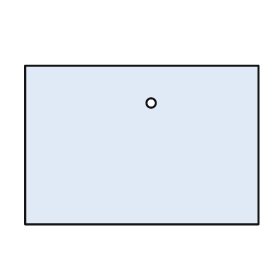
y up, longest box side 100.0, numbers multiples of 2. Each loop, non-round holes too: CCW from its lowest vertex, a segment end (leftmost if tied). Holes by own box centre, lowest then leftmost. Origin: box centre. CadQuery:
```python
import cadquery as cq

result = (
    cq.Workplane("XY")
    .moveTo(-50.0, -34.0)
    .lineTo(50.0, -34.0)
    .lineTo(50.0, 34.0)
    .lineTo(-50.0, 34.0)
    .close()
    .moveTo(4.0, 18.0)
    .circle(2.0)
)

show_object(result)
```